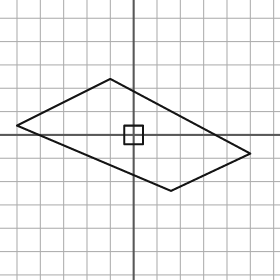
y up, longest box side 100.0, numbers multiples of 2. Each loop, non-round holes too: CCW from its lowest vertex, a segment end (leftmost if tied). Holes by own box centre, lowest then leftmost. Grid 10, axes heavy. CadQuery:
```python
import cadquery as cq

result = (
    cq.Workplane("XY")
    .moveTo(16.0, -24.0)
    .lineTo(50.0, -8.0)
    .lineTo(-10.0, 24.0)
    .lineTo(-50.0, 4.0)
    .close()
    .moveTo(-4.0, -4.0)
    .lineTo(4.0, -4.0)
    .lineTo(4.0, 4.0)
    .lineTo(-4.0, 4.0)
    .close()
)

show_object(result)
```